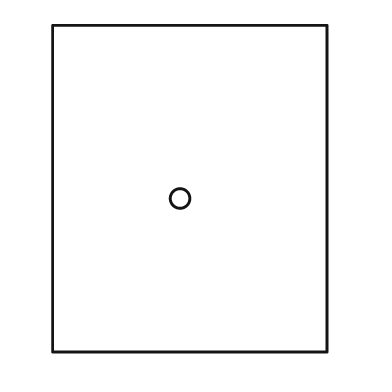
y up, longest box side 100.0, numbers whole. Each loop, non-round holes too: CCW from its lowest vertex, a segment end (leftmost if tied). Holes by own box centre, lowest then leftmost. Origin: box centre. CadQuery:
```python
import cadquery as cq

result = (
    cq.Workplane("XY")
    .moveTo(-42.0, -50.0)
    .lineTo(42.0, -50.0)
    .lineTo(42.0, 50.0)
    .lineTo(-42.0, 50.0)
    .close()
    .moveTo(-3.0, -3.0)
    .circle(3.0)
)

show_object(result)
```